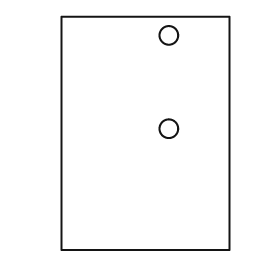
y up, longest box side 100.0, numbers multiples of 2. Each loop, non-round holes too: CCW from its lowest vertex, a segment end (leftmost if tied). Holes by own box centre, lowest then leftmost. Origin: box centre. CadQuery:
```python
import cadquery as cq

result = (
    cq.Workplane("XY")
    .moveTo(-36.0, -50.0)
    .lineTo(36.0, -50.0)
    .lineTo(36.0, 50.0)
    .lineTo(-36.0, 50.0)
    .close()
    .moveTo(10.0, 2.0)
    .circle(4.0)
    .moveTo(10.0, 42.0)
    .circle(4.0)
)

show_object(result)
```